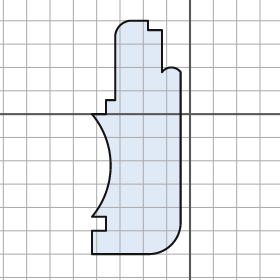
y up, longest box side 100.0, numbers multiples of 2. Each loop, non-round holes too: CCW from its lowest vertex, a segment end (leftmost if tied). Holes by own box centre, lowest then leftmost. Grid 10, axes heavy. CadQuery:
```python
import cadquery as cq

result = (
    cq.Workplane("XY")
    .moveTo(-42.0, -60.0)
    .lineTo(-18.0, -60.0)
    .threePointArc((-8.0, -56.0), (-4.0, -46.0))
    .lineTo(-4.0, 18.0)
    .threePointArc((-8.0, 20.0), (-12.0, 18.0))
    .lineTo(-12.0, 36.0)
    .lineTo(-18.0, 36.0)
    .lineTo(-18.0, 40.0)
    .lineTo(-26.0, 40.0)
    .threePointArc((-30.0, 38.0), (-32.0, 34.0))
    .lineTo(-32.0, 6.0)
    .lineTo(-36.0, 6.0)
    .lineTo(-36.0, 0.0)
    .lineTo(-42.0, 0.0)
    .threePointArc((-34.0, -22.0), (-42.0, -44.0))
    .lineTo(-36.0, -44.0)
    .lineTo(-36.0, -50.0)
    .lineTo(-42.0, -50.0)
    .close()
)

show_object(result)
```